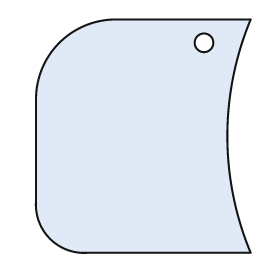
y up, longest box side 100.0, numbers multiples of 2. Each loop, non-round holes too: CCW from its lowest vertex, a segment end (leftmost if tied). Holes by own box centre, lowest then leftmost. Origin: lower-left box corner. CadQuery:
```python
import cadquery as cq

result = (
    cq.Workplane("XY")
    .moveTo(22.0, 0.0)
    .lineTo(92.0, 0.0)
    .threePointArc((82.0, 50.0), (92.0, 100.0))
    .lineTo(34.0, 100.0)
    .threePointArc((10.0, 90.0), (0.0, 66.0))
    .lineTo(0.0, 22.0)
    .threePointArc((6.0, 6.0), (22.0, 0.0))
    .close()
    .moveTo(72.0, 90.0)
    .circle(4.0)
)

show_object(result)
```